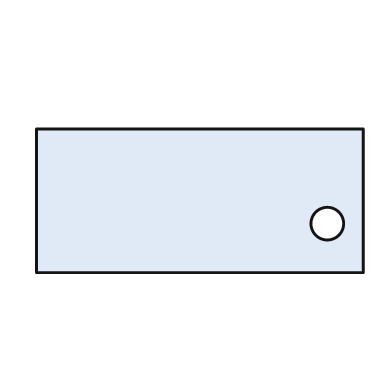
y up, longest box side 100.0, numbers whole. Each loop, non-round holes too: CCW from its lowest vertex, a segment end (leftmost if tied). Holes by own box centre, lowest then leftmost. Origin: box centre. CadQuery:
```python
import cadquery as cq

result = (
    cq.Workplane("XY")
    .moveTo(-50.0, -22.0)
    .lineTo(50.0, -22.0)
    .lineTo(50.0, 22.0)
    .lineTo(-50.0, 22.0)
    .close()
    .moveTo(39.0, -7.0)
    .circle(5.0)
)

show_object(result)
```